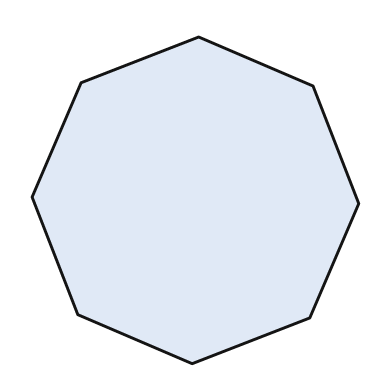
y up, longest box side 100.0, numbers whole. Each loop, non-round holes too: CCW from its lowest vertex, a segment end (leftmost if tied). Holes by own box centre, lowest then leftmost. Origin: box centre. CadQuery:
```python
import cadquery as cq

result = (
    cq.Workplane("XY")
    .moveTo(-1.0, -50.0)
    .lineTo(35.0, -36.0)
    .lineTo(50.0, -1.0)
    .lineTo(36.0, 35.0)
    .lineTo(1.0, 50.0)
    .lineTo(-35.0, 36.0)
    .lineTo(-50.0, 1.0)
    .lineTo(-36.0, -35.0)
    .close()
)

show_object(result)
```